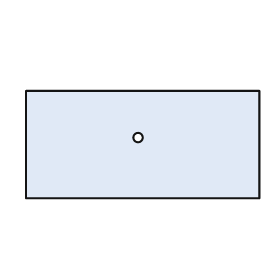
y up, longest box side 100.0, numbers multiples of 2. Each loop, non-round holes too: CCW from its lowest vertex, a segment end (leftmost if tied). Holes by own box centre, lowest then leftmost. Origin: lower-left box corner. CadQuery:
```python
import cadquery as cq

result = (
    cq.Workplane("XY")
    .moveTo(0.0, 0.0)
    .lineTo(100.0, 0.0)
    .lineTo(100.0, 46.0)
    .lineTo(0.0, 46.0)
    .close()
    .moveTo(48.0, 26.0)
    .circle(2.0)
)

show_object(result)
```